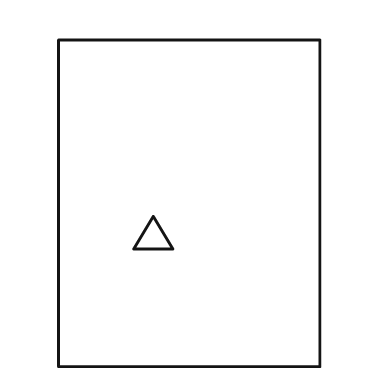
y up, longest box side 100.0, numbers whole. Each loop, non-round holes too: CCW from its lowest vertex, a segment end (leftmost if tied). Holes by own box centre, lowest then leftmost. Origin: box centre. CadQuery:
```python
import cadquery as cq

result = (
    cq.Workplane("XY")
    .moveTo(-40.0, -50.0)
    .lineTo(40.0, -50.0)
    .lineTo(40.0, 50.0)
    .lineTo(-40.0, 50.0)
    .close()
    .moveTo(-17.0, -14.0)
    .lineTo(-5.0, -14.0)
    .lineTo(-11.0, -4.0)
    .close()
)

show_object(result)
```